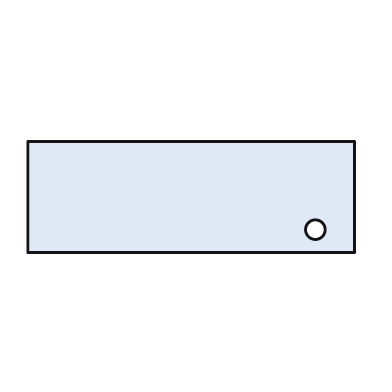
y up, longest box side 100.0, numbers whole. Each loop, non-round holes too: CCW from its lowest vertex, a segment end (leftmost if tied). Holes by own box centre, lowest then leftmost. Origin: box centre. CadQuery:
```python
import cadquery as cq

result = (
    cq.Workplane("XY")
    .moveTo(-50.0, -17.0)
    .lineTo(50.0, -17.0)
    .lineTo(50.0, 17.0)
    .lineTo(-50.0, 17.0)
    .close()
    .moveTo(38.0, -10.0)
    .circle(3.0)
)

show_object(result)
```